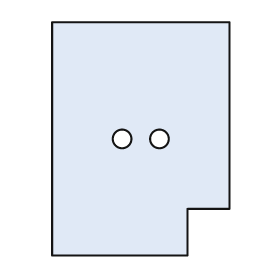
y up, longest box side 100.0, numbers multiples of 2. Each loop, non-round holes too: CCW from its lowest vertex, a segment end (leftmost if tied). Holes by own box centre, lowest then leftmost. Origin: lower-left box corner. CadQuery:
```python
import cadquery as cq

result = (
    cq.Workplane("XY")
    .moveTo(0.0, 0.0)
    .lineTo(58.0, 0.0)
    .lineTo(58.0, 20.0)
    .lineTo(76.0, 20.0)
    .lineTo(76.0, 100.0)
    .lineTo(0.0, 100.0)
    .close()
    .moveTo(30.0, 50.0)
    .circle(4.0)
    .moveTo(46.0, 50.0)
    .circle(4.0)
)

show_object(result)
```